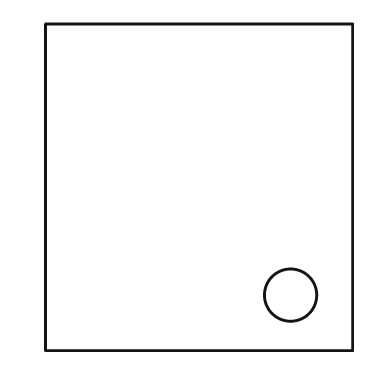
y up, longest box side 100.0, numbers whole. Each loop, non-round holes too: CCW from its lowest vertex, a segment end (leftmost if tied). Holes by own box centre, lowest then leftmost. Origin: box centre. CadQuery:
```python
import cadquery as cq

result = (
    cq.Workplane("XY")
    .moveTo(-47.0, -50.0)
    .lineTo(47.0, -50.0)
    .lineTo(47.0, 50.0)
    .lineTo(-47.0, 50.0)
    .close()
    .moveTo(28.0, -33.0)
    .circle(8.0)
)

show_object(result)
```